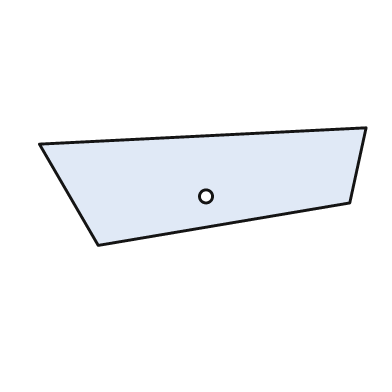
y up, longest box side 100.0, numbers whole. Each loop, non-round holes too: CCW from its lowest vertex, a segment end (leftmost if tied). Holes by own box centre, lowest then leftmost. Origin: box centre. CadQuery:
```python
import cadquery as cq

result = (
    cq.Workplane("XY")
    .moveTo(-32.0, -18.0)
    .lineTo(45.0, -5.0)
    .lineTo(50.0, 18.0)
    .lineTo(-50.0, 13.0)
    .close()
    .moveTo(1.0, -3.0)
    .circle(2.0)
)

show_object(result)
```